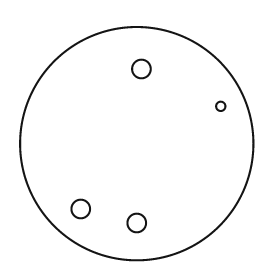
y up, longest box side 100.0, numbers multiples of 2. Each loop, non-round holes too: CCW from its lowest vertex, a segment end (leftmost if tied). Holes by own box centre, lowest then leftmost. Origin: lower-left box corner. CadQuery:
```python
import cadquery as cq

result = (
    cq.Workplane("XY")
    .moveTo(50.0, 50.0)
    .circle(50.0)
    .moveTo(50.0, 16.0)
    .circle(4.0)
    .moveTo(26.0, 22.0)
    .circle(4.0)
    .moveTo(86.0, 66.0)
    .circle(2.0)
    .moveTo(52.0, 82.0)
    .circle(4.0)
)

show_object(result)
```